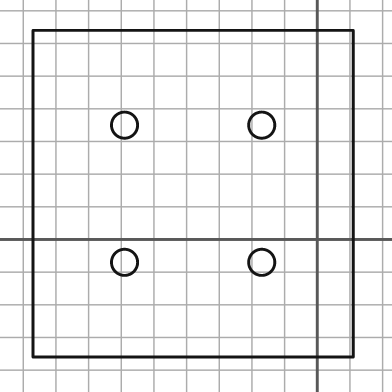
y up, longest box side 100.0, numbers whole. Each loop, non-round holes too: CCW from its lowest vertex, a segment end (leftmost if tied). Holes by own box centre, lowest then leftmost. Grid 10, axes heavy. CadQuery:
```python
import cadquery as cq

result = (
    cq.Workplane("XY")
    .moveTo(-87.0, -36.0)
    .lineTo(11.0, -36.0)
    .lineTo(11.0, 64.0)
    .lineTo(-87.0, 64.0)
    .close()
    .moveTo(-59.0, -7.0)
    .circle(4.0)
    .moveTo(-17.0, -7.0)
    .circle(4.0)
    .moveTo(-59.0, 35.0)
    .circle(4.0)
    .moveTo(-17.0, 35.0)
    .circle(4.0)
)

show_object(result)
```